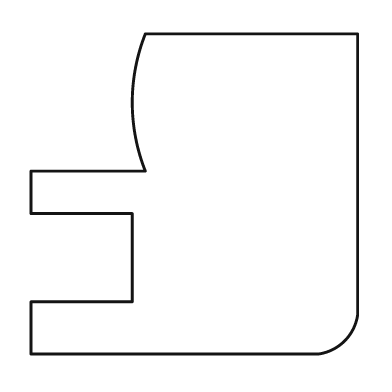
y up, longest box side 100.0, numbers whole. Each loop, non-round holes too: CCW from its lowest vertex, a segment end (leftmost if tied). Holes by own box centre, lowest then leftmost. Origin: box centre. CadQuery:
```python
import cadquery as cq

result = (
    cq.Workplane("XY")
    .moveTo(-50.0, -49.0)
    .lineTo(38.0, -49.0)
    .threePointArc((46.0, -45.0), (50.0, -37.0))
    .lineTo(50.0, 49.0)
    .lineTo(-15.0, 49.0)
    .threePointArc((-19.0, 28.0), (-15.0, 7.0))
    .lineTo(-50.0, 7.0)
    .lineTo(-50.0, -6.0)
    .lineTo(-19.0, -6.0)
    .lineTo(-19.0, -33.0)
    .lineTo(-50.0, -33.0)
    .close()
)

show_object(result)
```